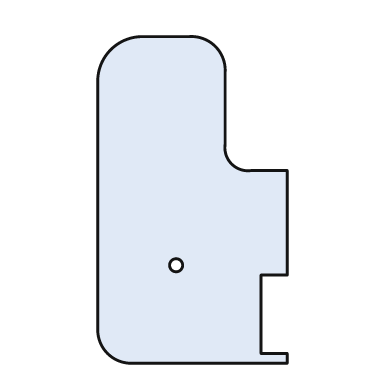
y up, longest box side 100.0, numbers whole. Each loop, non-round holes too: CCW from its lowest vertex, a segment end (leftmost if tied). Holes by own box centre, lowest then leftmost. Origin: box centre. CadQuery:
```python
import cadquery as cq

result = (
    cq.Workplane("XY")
    .moveTo(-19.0, -50.0)
    .lineTo(29.0, -50.0)
    .lineTo(29.0, -47.0)
    .lineTo(21.0, -47.0)
    .lineTo(21.0, -23.0)
    .lineTo(29.0, -23.0)
    .lineTo(29.0, 9.0)
    .lineTo(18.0, 9.0)
    .threePointArc((12.0, 11.0), (10.0, 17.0))
    .lineTo(10.0, 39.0)
    .threePointArc((7.0, 47.0), (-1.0, 50.0))
    .lineTo(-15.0, 50.0)
    .threePointArc((-25.0, 46.0), (-29.0, 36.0))
    .lineTo(-29.0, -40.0)
    .threePointArc((-26.0, -47.0), (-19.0, -50.0))
    .close()
    .moveTo(-5.0, -20.0)
    .circle(2.0)
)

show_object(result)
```